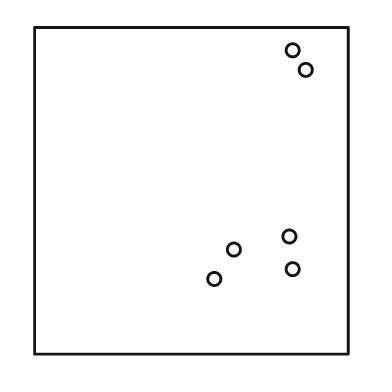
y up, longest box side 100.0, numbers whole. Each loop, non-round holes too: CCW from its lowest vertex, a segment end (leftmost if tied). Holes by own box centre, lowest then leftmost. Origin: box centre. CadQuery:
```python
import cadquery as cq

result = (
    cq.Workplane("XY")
    .moveTo(-48.0, -50.0)
    .lineTo(48.0, -50.0)
    .lineTo(48.0, 50.0)
    .lineTo(-48.0, 50.0)
    .close()
    .moveTo(7.0, -27.0)
    .circle(2.0)
    .moveTo(31.0, -24.0)
    .circle(2.0)
    .moveTo(13.0, -18.0)
    .circle(2.0)
    .moveTo(30.0, -14.0)
    .circle(2.0)
    .moveTo(35.0, 37.0)
    .circle(2.0)
    .moveTo(31.0, 43.0)
    .circle(2.0)
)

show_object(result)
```